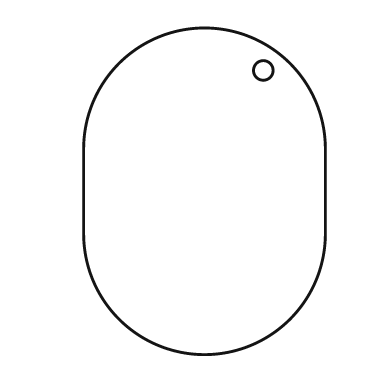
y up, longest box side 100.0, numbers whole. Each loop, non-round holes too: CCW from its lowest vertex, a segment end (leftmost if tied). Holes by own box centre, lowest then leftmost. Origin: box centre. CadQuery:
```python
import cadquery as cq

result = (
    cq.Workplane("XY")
    .moveTo(-37.0, -13.0)
    .threePointArc((0.0, -50.0), (37.0, -13.0))
    .lineTo(37.0, 13.0)
    .threePointArc((0.0, 50.0), (-37.0, 13.0))
    .close()
    .moveTo(18.0, 37.0)
    .circle(3.0)
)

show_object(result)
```